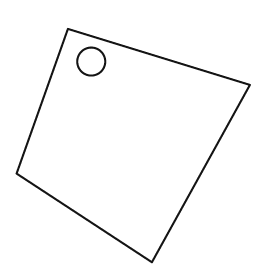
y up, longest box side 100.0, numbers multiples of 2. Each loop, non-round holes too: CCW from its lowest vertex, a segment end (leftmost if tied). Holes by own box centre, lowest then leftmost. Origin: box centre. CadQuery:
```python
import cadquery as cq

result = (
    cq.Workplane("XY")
    .moveTo(8.0, -50.0)
    .lineTo(50.0, 26.0)
    .lineTo(-28.0, 50.0)
    .lineTo(-50.0, -12.0)
    .close()
    .moveTo(-18.0, 36.0)
    .circle(6.0)
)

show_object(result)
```